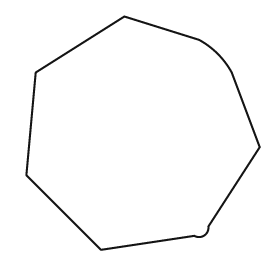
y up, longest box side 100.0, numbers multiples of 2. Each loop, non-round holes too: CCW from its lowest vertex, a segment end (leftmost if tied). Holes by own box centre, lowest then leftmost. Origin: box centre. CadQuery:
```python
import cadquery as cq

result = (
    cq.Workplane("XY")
    .moveTo(-18.0, -50.0)
    .lineTo(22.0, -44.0)
    .threePointArc((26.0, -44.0), (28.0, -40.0))
    .lineTo(50.0, -6.0)
    .lineTo(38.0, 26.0)
    .threePointArc((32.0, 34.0), (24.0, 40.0))
    .lineTo(-8.0, 50.0)
    .lineTo(-46.0, 26.0)
    .lineTo(-50.0, -18.0)
    .close()
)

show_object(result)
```